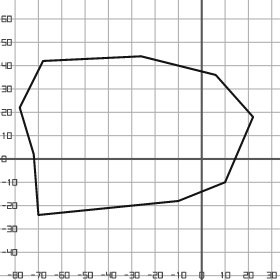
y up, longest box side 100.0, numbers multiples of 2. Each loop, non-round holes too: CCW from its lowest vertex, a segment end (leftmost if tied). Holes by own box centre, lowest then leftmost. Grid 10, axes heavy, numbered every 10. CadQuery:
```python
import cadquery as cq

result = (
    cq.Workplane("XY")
    .moveTo(-70.0, -24.0)
    .lineTo(-10.0, -18.0)
    .lineTo(10.0, -10.0)
    .lineTo(22.0, 18.0)
    .lineTo(6.0, 36.0)
    .lineTo(-26.0, 44.0)
    .lineTo(-68.0, 42.0)
    .lineTo(-78.0, 22.0)
    .lineTo(-72.0, 2.0)
    .close()
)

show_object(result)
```